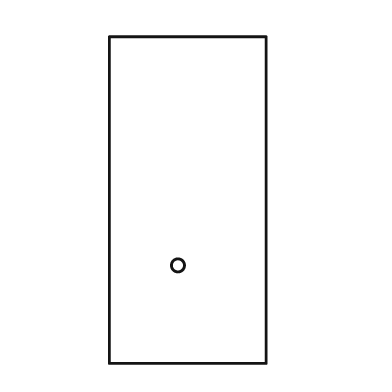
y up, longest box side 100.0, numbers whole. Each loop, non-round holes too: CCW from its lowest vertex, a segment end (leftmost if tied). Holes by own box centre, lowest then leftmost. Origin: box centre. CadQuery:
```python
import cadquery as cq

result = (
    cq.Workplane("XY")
    .moveTo(-24.0, -50.0)
    .lineTo(24.0, -50.0)
    .lineTo(24.0, 50.0)
    .lineTo(-24.0, 50.0)
    .close()
    .moveTo(-3.0, -20.0)
    .circle(2.0)
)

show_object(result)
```